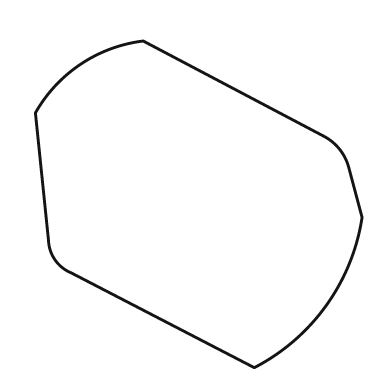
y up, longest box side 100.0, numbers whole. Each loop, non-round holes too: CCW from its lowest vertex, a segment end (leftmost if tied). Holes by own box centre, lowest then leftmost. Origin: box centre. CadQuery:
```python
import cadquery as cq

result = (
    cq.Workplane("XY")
    .moveTo(17.0, -50.0)
    .threePointArc((39.0, -31.0), (50.0, -4.0))
    .lineTo(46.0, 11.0)
    .threePointArc((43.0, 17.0), (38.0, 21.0))
    .lineTo(-17.0, 50.0)
    .threePointArc((-36.0, 43.0), (-50.0, 28.0))
    .lineTo(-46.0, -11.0)
    .threePointArc((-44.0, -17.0), (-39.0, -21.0))
    .close()
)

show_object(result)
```